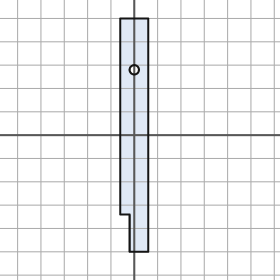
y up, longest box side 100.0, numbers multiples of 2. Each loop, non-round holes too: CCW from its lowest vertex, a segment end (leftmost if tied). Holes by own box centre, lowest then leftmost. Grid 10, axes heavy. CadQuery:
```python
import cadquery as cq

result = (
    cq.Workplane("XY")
    .moveTo(-2.0, -50.0)
    .lineTo(6.0, -50.0)
    .lineTo(6.0, 50.0)
    .lineTo(-6.0, 50.0)
    .lineTo(-6.0, -34.0)
    .lineTo(-2.0, -34.0)
    .close()
    .moveTo(0.0, 28.0)
    .circle(2.0)
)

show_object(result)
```